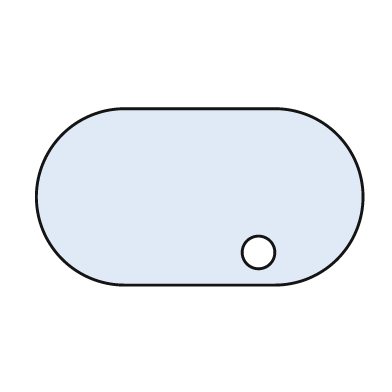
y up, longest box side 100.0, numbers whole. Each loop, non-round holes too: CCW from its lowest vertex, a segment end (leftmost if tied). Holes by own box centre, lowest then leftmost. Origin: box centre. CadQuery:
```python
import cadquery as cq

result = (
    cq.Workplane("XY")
    .moveTo(-23.0, -27.0)
    .lineTo(23.0, -27.0)
    .threePointArc((50.0, 0.0), (23.0, 27.0))
    .lineTo(-23.0, 27.0)
    .threePointArc((-50.0, 0.0), (-23.0, -27.0))
    .close()
    .moveTo(18.0, -17.0)
    .circle(5.0)
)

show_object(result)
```